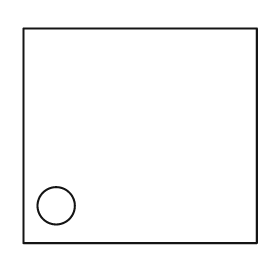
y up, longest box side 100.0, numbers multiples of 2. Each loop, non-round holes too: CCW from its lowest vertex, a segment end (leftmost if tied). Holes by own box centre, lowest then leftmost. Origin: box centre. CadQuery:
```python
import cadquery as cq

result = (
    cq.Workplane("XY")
    .moveTo(-50.0, -46.0)
    .lineTo(50.0, -46.0)
    .lineTo(50.0, 46.0)
    .lineTo(-50.0, 46.0)
    .close()
    .moveTo(-36.0, -30.0)
    .circle(8.0)
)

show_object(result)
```